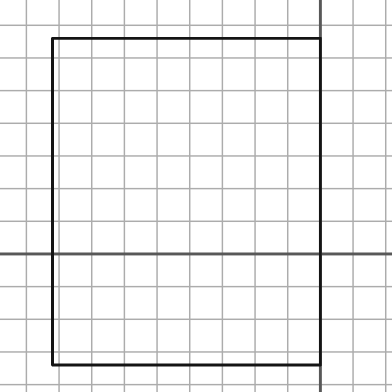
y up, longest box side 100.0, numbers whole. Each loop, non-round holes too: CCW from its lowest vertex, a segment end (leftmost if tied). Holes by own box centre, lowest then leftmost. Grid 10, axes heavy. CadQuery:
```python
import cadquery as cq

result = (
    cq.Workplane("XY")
    .moveTo(-82.0, -34.0)
    .lineTo(0.0, -34.0)
    .lineTo(0.0, 66.0)
    .lineTo(-82.0, 66.0)
    .close()
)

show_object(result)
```